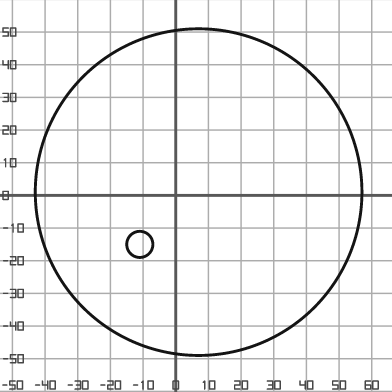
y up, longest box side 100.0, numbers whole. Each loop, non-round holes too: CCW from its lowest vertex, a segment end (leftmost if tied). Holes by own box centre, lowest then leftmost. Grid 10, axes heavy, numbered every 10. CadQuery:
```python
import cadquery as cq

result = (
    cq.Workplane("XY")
    .moveTo(7.0, 1.0)
    .circle(50.0)
    .moveTo(-11.0, -15.0)
    .circle(4.0)
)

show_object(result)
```